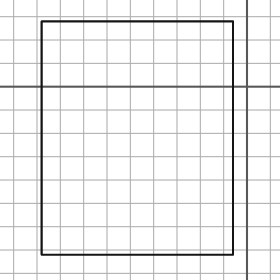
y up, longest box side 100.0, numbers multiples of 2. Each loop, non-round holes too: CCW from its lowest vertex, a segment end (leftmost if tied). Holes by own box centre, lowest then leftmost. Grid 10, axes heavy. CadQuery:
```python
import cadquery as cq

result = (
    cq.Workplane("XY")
    .moveTo(-88.0, -72.0)
    .lineTo(-6.0, -72.0)
    .lineTo(-6.0, 28.0)
    .lineTo(-88.0, 28.0)
    .close()
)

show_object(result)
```